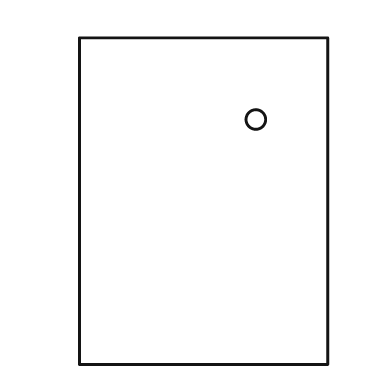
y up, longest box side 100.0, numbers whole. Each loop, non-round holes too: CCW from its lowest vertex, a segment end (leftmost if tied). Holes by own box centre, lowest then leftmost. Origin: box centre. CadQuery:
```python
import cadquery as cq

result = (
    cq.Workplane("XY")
    .moveTo(-38.0, -50.0)
    .lineTo(38.0, -50.0)
    .lineTo(38.0, 50.0)
    .lineTo(-38.0, 50.0)
    .close()
    .moveTo(16.0, 25.0)
    .circle(3.0)
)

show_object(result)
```